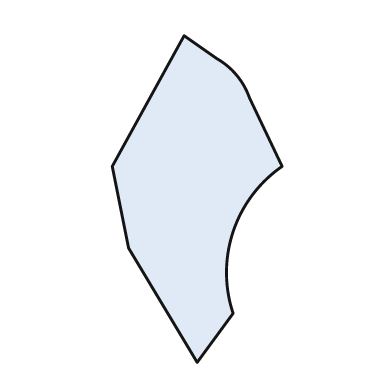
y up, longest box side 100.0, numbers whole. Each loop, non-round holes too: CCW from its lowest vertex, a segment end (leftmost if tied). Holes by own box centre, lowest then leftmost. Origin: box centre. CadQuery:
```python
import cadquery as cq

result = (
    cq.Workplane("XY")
    .moveTo(0.0, -50.0)
    .lineTo(11.0, -35.0)
    .threePointArc((11.0, -10.0), (26.0, 10.0))
    .lineTo(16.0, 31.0)
    .threePointArc((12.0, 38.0), (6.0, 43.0))
    .lineTo(-4.0, 50.0)
    .lineTo(-26.0, 10.0)
    .lineTo(-21.0, -15.0)
    .close()
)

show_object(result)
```